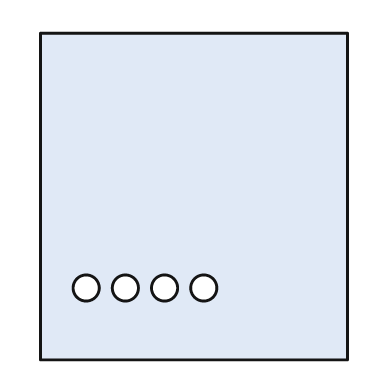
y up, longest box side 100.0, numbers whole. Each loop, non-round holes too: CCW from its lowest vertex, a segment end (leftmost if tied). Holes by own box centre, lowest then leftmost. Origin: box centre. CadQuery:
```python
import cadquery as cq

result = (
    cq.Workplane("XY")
    .moveTo(-47.0, -50.0)
    .lineTo(47.0, -50.0)
    .lineTo(47.0, 50.0)
    .lineTo(-47.0, 50.0)
    .close()
    .moveTo(-33.0, -28.0)
    .circle(4.0)
    .moveTo(-21.0, -28.0)
    .circle(4.0)
    .moveTo(-9.0, -28.0)
    .circle(4.0)
    .moveTo(3.0, -28.0)
    .circle(4.0)
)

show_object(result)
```